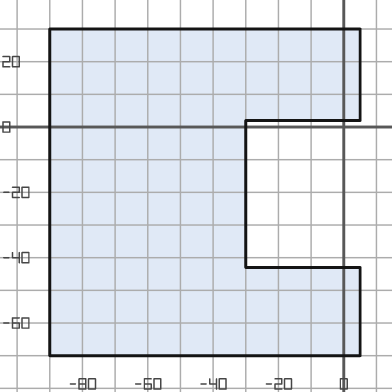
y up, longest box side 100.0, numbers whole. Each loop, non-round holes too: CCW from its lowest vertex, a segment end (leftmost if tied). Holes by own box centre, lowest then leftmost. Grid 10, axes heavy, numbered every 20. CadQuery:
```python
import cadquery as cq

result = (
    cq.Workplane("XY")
    .moveTo(-90.0, -70.0)
    .lineTo(5.0, -70.0)
    .lineTo(5.0, -43.0)
    .lineTo(-30.0, -43.0)
    .lineTo(-30.0, 2.0)
    .lineTo(5.0, 2.0)
    .lineTo(5.0, 30.0)
    .lineTo(-90.0, 30.0)
    .close()
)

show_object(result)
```